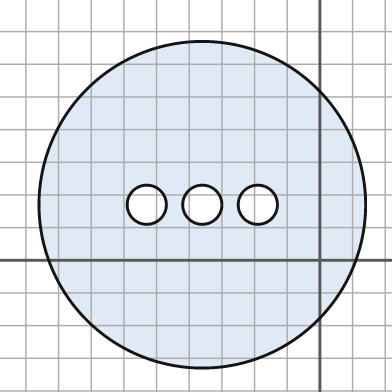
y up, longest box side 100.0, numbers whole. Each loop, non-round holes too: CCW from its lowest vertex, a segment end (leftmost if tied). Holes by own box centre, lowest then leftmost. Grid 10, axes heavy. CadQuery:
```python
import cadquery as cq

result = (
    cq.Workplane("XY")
    .moveTo(-36.0, 17.0)
    .circle(50.0)
    .moveTo(-53.0, 17.0)
    .circle(6.0)
    .moveTo(-36.0, 17.0)
    .circle(6.0)
    .moveTo(-19.0, 17.0)
    .circle(6.0)
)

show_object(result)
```